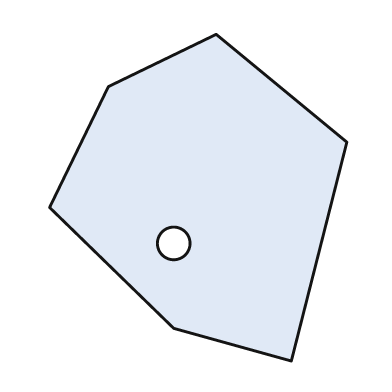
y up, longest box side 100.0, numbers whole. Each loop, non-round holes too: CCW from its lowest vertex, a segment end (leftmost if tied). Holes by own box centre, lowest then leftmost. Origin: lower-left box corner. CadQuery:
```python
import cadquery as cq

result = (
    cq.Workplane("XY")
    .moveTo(74.0, 0.0)
    .lineTo(91.0, 67.0)
    .lineTo(51.0, 100.0)
    .lineTo(18.0, 84.0)
    .lineTo(0.0, 47.0)
    .lineTo(38.0, 10.0)
    .close()
    .moveTo(38.0, 36.0)
    .circle(5.0)
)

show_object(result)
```